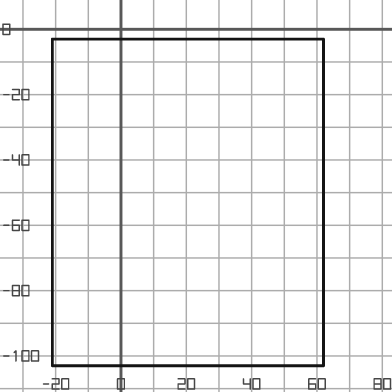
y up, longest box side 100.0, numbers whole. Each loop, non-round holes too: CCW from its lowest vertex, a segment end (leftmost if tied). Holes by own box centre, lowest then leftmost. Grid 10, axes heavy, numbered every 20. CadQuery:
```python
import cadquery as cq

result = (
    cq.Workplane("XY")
    .moveTo(-21.0, -103.0)
    .lineTo(62.0, -103.0)
    .lineTo(62.0, -3.0)
    .lineTo(-21.0, -3.0)
    .close()
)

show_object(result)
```